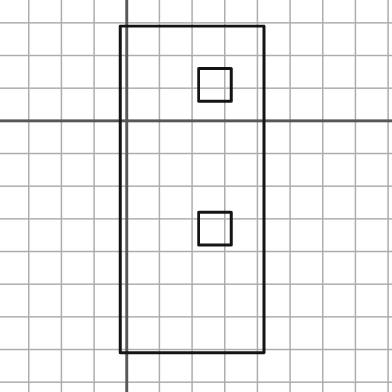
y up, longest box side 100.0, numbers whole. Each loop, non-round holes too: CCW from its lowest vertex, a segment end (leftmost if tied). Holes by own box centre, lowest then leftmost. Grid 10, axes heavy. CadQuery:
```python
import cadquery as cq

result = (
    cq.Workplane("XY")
    .moveTo(-2.0, -71.0)
    .lineTo(42.0, -71.0)
    .lineTo(42.0, 29.0)
    .lineTo(-2.0, 29.0)
    .close()
    .moveTo(22.0, -38.0)
    .lineTo(32.0, -38.0)
    .lineTo(32.0, -28.0)
    .lineTo(22.0, -28.0)
    .close()
    .moveTo(22.0, 6.0)
    .lineTo(32.0, 6.0)
    .lineTo(32.0, 16.0)
    .lineTo(22.0, 16.0)
    .close()
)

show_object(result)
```